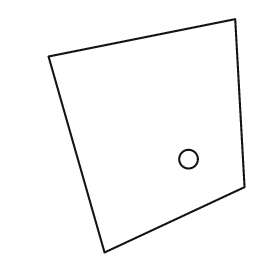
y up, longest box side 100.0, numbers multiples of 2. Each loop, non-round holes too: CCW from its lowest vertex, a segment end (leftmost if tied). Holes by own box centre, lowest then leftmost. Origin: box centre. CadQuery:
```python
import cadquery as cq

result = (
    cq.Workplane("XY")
    .moveTo(-18.0, -50.0)
    .lineTo(42.0, -22.0)
    .lineTo(38.0, 50.0)
    .lineTo(-42.0, 34.0)
    .close()
    .moveTo(18.0, -10.0)
    .circle(4.0)
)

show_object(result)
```